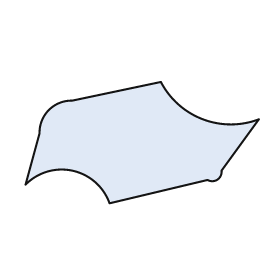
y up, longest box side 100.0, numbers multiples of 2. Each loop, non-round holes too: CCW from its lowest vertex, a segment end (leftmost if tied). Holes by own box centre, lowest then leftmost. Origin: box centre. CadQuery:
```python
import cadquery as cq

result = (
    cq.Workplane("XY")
    .moveTo(-14.0, -26.0)
    .lineTo(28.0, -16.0)
    .threePointArc((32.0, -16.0), (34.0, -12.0))
    .lineTo(50.0, 10.0)
    .threePointArc((26.0, 10.0), (8.0, 26.0))
    .lineTo(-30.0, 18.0)
    .threePointArc((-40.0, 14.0), (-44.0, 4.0))
    .lineTo(-50.0, -18.0)
    .threePointArc((-30.0, -12.0), (-14.0, -26.0))
    .close()
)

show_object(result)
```